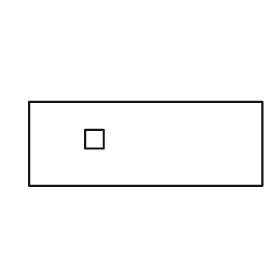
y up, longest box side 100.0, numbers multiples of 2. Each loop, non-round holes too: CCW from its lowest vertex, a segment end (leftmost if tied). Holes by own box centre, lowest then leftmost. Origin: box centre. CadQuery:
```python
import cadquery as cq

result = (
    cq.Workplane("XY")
    .moveTo(-50.0, -18.0)
    .lineTo(50.0, -18.0)
    .lineTo(50.0, 18.0)
    .lineTo(-50.0, 18.0)
    .close()
    .moveTo(-26.0, -2.0)
    .lineTo(-18.0, -2.0)
    .lineTo(-18.0, 6.0)
    .lineTo(-26.0, 6.0)
    .close()
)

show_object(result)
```